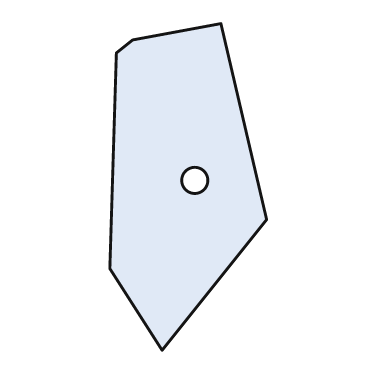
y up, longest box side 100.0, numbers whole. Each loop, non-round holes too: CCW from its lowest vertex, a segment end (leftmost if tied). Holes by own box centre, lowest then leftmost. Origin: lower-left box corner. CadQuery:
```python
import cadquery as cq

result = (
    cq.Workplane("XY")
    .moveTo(16.0, 0.0)
    .lineTo(48.0, 40.0)
    .lineTo(34.0, 100.0)
    .lineTo(7.0, 95.0)
    .lineTo(2.0, 91.0)
    .lineTo(0.0, 25.0)
    .close()
    .moveTo(26.0, 52.0)
    .circle(4.0)
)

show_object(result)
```